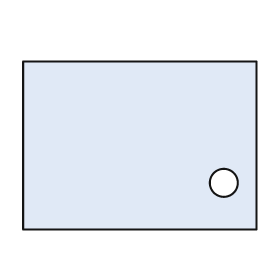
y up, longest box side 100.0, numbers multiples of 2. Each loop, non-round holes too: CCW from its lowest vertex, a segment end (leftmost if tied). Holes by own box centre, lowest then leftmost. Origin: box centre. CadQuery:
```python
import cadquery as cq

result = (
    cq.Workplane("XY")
    .moveTo(-50.0, -36.0)
    .lineTo(50.0, -36.0)
    .lineTo(50.0, 36.0)
    .lineTo(-50.0, 36.0)
    .close()
    .moveTo(36.0, -16.0)
    .circle(6.0)
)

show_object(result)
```